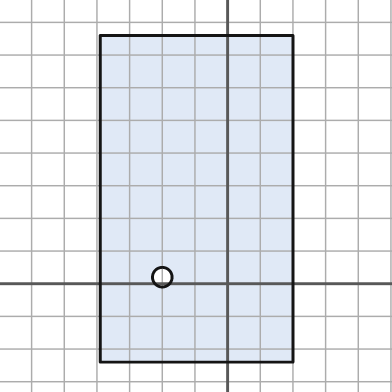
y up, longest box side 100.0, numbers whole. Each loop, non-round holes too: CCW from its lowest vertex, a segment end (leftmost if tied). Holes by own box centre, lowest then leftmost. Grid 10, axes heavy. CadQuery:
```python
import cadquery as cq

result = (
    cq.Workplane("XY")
    .moveTo(-39.0, -24.0)
    .lineTo(20.0, -24.0)
    .lineTo(20.0, 76.0)
    .lineTo(-39.0, 76.0)
    .close()
    .moveTo(-20.0, 2.0)
    .circle(3.0)
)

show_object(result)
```